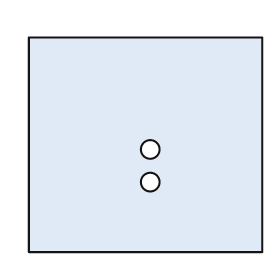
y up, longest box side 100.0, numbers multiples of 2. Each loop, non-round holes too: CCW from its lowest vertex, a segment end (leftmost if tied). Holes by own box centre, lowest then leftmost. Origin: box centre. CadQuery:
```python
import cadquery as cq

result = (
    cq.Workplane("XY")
    .moveTo(-50.0, -46.0)
    .lineTo(50.0, -46.0)
    .lineTo(50.0, 46.0)
    .lineTo(-50.0, 46.0)
    .close()
    .moveTo(2.0, -16.0)
    .circle(4.0)
    .moveTo(2.0, -2.0)
    .circle(4.0)
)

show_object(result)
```